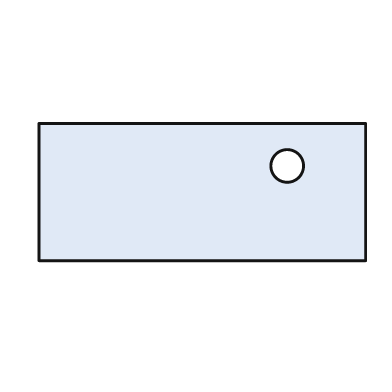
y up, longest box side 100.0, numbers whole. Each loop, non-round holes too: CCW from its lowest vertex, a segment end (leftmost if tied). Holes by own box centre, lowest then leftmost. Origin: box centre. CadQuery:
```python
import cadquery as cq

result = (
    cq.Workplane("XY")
    .moveTo(-50.0, -21.0)
    .lineTo(50.0, -21.0)
    .lineTo(50.0, 21.0)
    .lineTo(-50.0, 21.0)
    .close()
    .moveTo(26.0, 8.0)
    .circle(5.0)
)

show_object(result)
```